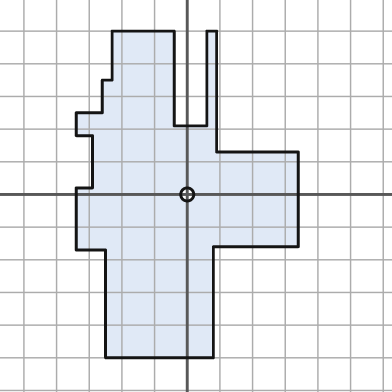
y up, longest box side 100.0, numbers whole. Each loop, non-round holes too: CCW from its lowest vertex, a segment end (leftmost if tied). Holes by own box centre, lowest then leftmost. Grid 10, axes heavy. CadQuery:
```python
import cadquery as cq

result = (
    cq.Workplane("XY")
    .moveTo(-25.0, -50.0)
    .lineTo(8.0, -50.0)
    .lineTo(8.0, -16.0)
    .lineTo(34.0, -16.0)
    .lineTo(34.0, 13.0)
    .lineTo(9.0, 13.0)
    .lineTo(9.0, 50.0)
    .lineTo(6.0, 50.0)
    .lineTo(6.0, 21.0)
    .lineTo(-4.0, 21.0)
    .lineTo(-4.0, 50.0)
    .lineTo(-23.0, 50.0)
    .lineTo(-23.0, 35.0)
    .lineTo(-26.0, 35.0)
    .lineTo(-26.0, 25.0)
    .lineTo(-34.0, 25.0)
    .lineTo(-34.0, 18.0)
    .lineTo(-29.0, 18.0)
    .lineTo(-29.0, 2.0)
    .lineTo(-34.0, 2.0)
    .lineTo(-34.0, -17.0)
    .lineTo(-25.0, -17.0)
    .close()
    .moveTo(0.0, 0.0)
    .circle(2.0)
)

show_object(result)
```